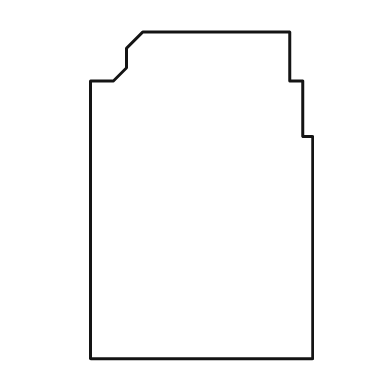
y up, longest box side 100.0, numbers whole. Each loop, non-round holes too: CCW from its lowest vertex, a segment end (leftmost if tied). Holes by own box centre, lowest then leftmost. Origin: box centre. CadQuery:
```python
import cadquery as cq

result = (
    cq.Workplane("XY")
    .moveTo(-34.0, -50.0)
    .lineTo(34.0, -50.0)
    .lineTo(34.0, 18.0)
    .lineTo(31.0, 18.0)
    .lineTo(31.0, 35.0)
    .lineTo(27.0, 35.0)
    .lineTo(27.0, 50.0)
    .lineTo(-18.0, 50.0)
    .lineTo(-23.0, 45.0)
    .lineTo(-23.0, 39.0)
    .lineTo(-27.0, 35.0)
    .lineTo(-34.0, 35.0)
    .close()
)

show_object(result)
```